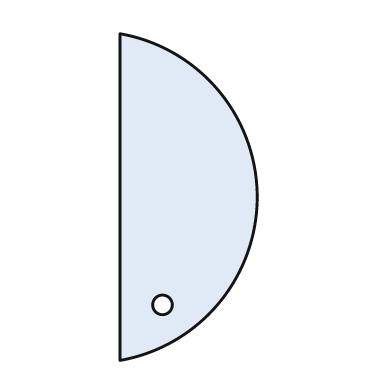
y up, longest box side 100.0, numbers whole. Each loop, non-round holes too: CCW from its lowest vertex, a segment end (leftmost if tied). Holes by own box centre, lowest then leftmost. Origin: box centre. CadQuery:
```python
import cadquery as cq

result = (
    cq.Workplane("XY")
    .moveTo(-21.0, -50.0)
    .threePointArc((21.0, 0.0), (-21.0, 50.0))
    .close()
    .moveTo(-8.0, -33.0)
    .circle(3.0)
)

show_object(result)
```